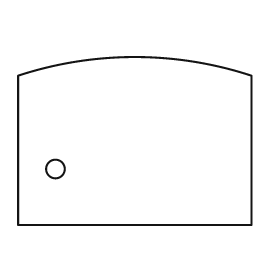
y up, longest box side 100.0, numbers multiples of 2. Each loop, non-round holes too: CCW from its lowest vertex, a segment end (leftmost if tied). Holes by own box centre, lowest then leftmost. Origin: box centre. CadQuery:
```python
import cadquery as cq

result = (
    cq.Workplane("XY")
    .moveTo(-50.0, -36.0)
    .lineTo(50.0, -36.0)
    .lineTo(50.0, 28.0)
    .threePointArc((0.0, 36.0), (-50.0, 28.0))
    .close()
    .moveTo(-34.0, -12.0)
    .circle(4.0)
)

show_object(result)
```